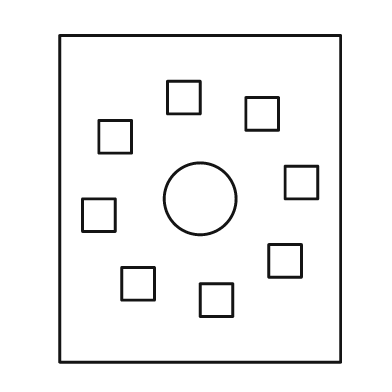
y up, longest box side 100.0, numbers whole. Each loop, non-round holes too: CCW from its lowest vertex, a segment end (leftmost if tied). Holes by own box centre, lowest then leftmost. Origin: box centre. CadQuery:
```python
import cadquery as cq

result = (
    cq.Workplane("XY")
    .moveTo(-43.0, -50.0)
    .lineTo(43.0, -50.0)
    .lineTo(43.0, 50.0)
    .lineTo(-43.0, 50.0)
    .close()
    .moveTo(0.0, -36.0)
    .lineTo(10.0, -36.0)
    .lineTo(10.0, -26.0)
    .lineTo(0.0, -26.0)
    .close()
    .moveTo(-24.0, -31.0)
    .lineTo(-14.0, -31.0)
    .lineTo(-14.0, -21.0)
    .lineTo(-24.0, -21.0)
    .close()
    .moveTo(21.0, -24.0)
    .lineTo(31.0, -24.0)
    .lineTo(31.0, -14.0)
    .lineTo(21.0, -14.0)
    .close()
    .moveTo(-36.0, -10.0)
    .lineTo(-26.0, -10.0)
    .lineTo(-26.0, 0.0)
    .lineTo(-36.0, 0.0)
    .close()
    .moveTo(0.0, 0.0)
    .circle(11.0)
    .moveTo(26.0, 0.0)
    .lineTo(36.0, 0.0)
    .lineTo(36.0, 10.0)
    .lineTo(26.0, 10.0)
    .close()
    .moveTo(-31.0, 14.0)
    .lineTo(-21.0, 14.0)
    .lineTo(-21.0, 24.0)
    .lineTo(-31.0, 24.0)
    .close()
    .moveTo(14.0, 21.0)
    .lineTo(24.0, 21.0)
    .lineTo(24.0, 31.0)
    .lineTo(14.0, 31.0)
    .close()
    .moveTo(-10.0, 26.0)
    .lineTo(0.0, 26.0)
    .lineTo(0.0, 36.0)
    .lineTo(-10.0, 36.0)
    .close()
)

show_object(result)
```